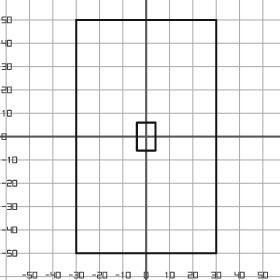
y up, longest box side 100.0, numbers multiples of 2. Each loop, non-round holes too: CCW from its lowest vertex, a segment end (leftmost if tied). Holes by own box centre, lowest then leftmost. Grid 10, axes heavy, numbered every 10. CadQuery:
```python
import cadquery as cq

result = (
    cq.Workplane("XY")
    .moveTo(-30.0, -50.0)
    .lineTo(30.0, -50.0)
    .lineTo(30.0, 50.0)
    .lineTo(-30.0, 50.0)
    .close()
    .moveTo(-4.0, -6.0)
    .lineTo(4.0, -6.0)
    .lineTo(4.0, 6.0)
    .lineTo(-4.0, 6.0)
    .close()
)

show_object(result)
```